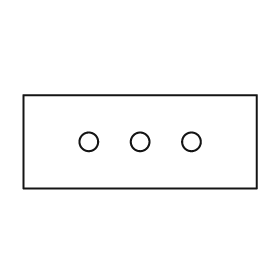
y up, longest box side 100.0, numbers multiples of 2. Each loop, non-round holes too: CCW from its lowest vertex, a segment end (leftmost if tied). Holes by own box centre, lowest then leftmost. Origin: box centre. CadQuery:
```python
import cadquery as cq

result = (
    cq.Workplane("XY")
    .moveTo(-50.0, -20.0)
    .lineTo(50.0, -20.0)
    .lineTo(50.0, 20.0)
    .lineTo(-50.0, 20.0)
    .close()
    .moveTo(-22.0, 0.0)
    .circle(4.0)
    .moveTo(0.0, 0.0)
    .circle(4.0)
    .moveTo(22.0, 0.0)
    .circle(4.0)
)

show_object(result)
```